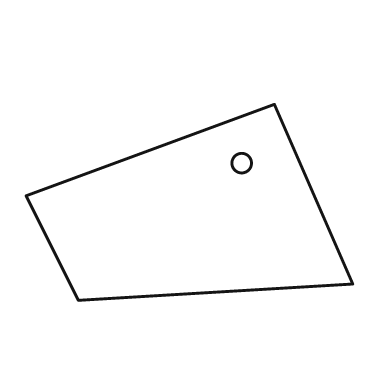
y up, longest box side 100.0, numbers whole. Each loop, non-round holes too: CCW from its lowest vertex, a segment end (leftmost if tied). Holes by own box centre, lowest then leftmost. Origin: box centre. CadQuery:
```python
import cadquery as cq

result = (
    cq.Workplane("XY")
    .moveTo(-34.0, -30.0)
    .lineTo(50.0, -25.0)
    .lineTo(26.0, 30.0)
    .lineTo(-50.0, 2.0)
    .close()
    .moveTo(16.0, 12.0)
    .circle(3.0)
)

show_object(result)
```